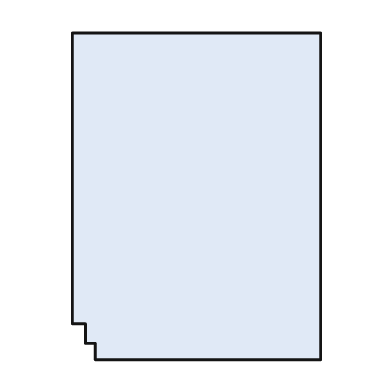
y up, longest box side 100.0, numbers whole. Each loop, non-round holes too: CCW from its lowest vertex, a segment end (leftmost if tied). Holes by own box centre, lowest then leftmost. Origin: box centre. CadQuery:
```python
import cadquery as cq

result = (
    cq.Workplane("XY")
    .moveTo(-31.0, -50.0)
    .lineTo(38.0, -50.0)
    .lineTo(38.0, 50.0)
    .lineTo(-38.0, 50.0)
    .lineTo(-38.0, -39.0)
    .lineTo(-34.0, -39.0)
    .lineTo(-34.0, -45.0)
    .lineTo(-31.0, -45.0)
    .close()
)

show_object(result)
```